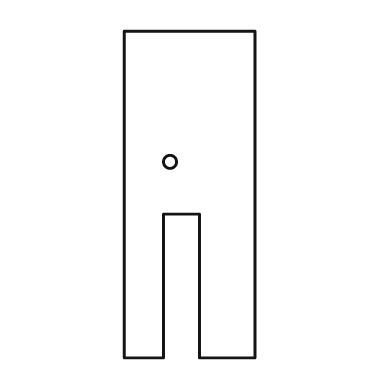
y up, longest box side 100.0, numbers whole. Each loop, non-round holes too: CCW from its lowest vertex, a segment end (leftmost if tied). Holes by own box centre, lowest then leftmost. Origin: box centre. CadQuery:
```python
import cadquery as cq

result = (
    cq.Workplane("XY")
    .moveTo(-20.0, -50.0)
    .lineTo(-8.0, -50.0)
    .lineTo(-8.0, -6.0)
    .lineTo(3.0, -6.0)
    .lineTo(3.0, -50.0)
    .lineTo(20.0, -50.0)
    .lineTo(20.0, 50.0)
    .lineTo(-20.0, 50.0)
    .close()
    .moveTo(-6.0, 10.0)
    .circle(2.0)
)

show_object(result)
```